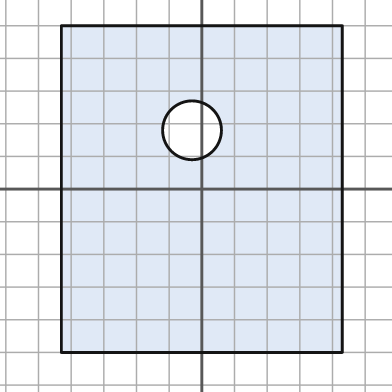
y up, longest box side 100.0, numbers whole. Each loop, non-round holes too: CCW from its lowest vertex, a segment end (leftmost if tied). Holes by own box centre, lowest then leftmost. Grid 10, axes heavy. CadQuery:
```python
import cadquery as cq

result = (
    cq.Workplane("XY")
    .moveTo(-43.0, -50.0)
    .lineTo(43.0, -50.0)
    .lineTo(43.0, 50.0)
    .lineTo(-43.0, 50.0)
    .close()
    .moveTo(-3.0, 18.0)
    .circle(9.0)
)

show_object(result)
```